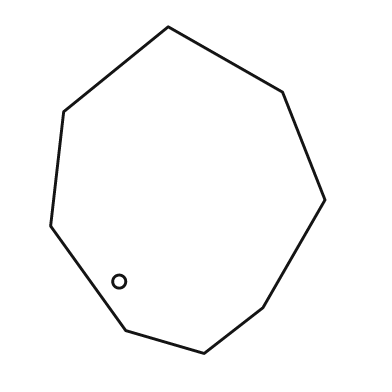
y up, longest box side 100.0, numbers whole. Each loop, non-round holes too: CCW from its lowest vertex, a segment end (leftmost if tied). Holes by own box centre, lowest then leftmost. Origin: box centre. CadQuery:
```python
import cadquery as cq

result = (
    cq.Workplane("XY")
    .moveTo(5.0, -50.0)
    .lineTo(23.0, -36.0)
    .lineTo(42.0, -3.0)
    .lineTo(29.0, 30.0)
    .lineTo(-6.0, 50.0)
    .lineTo(-38.0, 24.0)
    .lineTo(-42.0, -11.0)
    .lineTo(-19.0, -43.0)
    .close()
    .moveTo(-21.0, -28.0)
    .circle(2.0)
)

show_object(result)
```